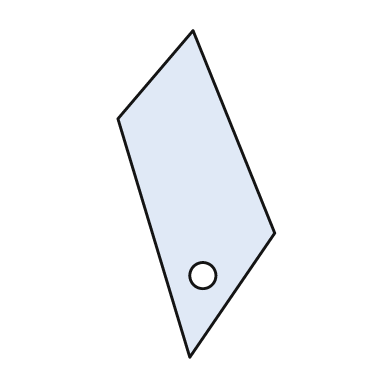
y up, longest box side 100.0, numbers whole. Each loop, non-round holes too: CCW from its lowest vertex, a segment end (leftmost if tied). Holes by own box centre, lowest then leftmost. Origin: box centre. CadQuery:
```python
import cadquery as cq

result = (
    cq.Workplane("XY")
    .moveTo(-2.0, -50.0)
    .lineTo(24.0, -12.0)
    .lineTo(-1.0, 50.0)
    .lineTo(-24.0, 23.0)
    .close()
    .moveTo(2.0, -25.0)
    .circle(4.0)
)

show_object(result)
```